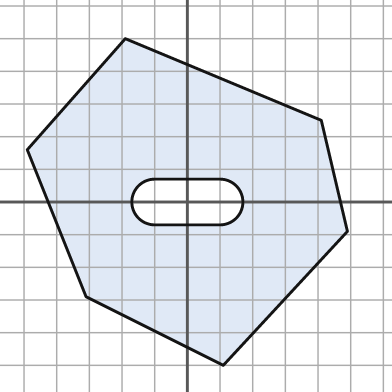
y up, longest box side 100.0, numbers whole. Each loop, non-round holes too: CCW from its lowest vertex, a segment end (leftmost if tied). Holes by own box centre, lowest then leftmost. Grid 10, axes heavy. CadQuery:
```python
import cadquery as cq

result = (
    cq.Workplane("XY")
    .moveTo(11.0, -50.0)
    .lineTo(49.0, -9.0)
    .lineTo(41.0, 25.0)
    .lineTo(-19.0, 50.0)
    .lineTo(-49.0, 16.0)
    .lineTo(-31.0, -29.0)
    .close()
    .moveTo(-10.0, -7.0)
    .lineTo(10.0, -7.0)
    .threePointArc((17.0, 0.0), (10.0, 7.0))
    .lineTo(-10.0, 7.0)
    .threePointArc((-17.0, 0.0), (-10.0, -7.0))
    .close()
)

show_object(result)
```